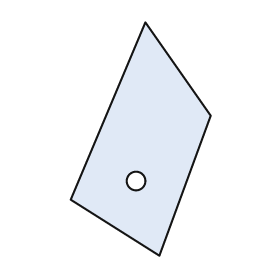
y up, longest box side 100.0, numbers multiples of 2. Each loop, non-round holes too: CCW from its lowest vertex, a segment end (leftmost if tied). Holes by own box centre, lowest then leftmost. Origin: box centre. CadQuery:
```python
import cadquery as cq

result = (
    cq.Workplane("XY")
    .moveTo(8.0, -50.0)
    .lineTo(30.0, 10.0)
    .lineTo(2.0, 50.0)
    .lineTo(-30.0, -26.0)
    .close()
    .moveTo(-2.0, -18.0)
    .circle(4.0)
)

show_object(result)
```